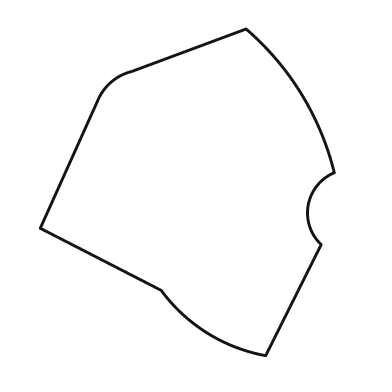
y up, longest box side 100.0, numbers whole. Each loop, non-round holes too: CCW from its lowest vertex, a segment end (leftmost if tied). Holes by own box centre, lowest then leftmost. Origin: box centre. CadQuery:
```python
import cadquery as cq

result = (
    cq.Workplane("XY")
    .moveTo(24.0, -50.0)
    .lineTo(41.0, -16.0)
    .threePointArc((37.0, -4.0), (45.0, 6.0))
    .threePointArc((35.0, 30.0), (18.0, 50.0))
    .lineTo(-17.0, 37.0)
    .threePointArc((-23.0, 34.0), (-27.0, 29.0))
    .lineTo(-45.0, -11.0)
    .lineTo(-8.0, -30.0)
    .threePointArc((6.0, -43.0), (24.0, -50.0))
    .close()
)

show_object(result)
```